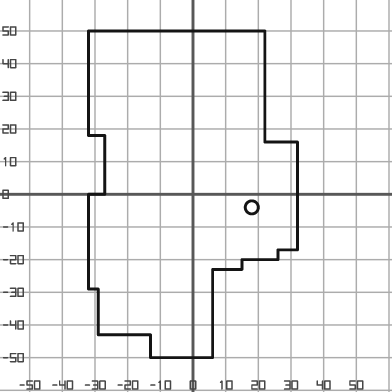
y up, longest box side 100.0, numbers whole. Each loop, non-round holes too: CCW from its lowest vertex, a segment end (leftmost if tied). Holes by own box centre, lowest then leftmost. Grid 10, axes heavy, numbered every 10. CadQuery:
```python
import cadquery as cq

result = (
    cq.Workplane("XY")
    .moveTo(-13.0, -50.0)
    .lineTo(6.0, -50.0)
    .lineTo(6.0, -23.0)
    .lineTo(15.0, -23.0)
    .lineTo(15.0, -20.0)
    .lineTo(26.0, -20.0)
    .lineTo(26.0, -17.0)
    .lineTo(32.0, -17.0)
    .lineTo(32.0, 16.0)
    .lineTo(22.0, 16.0)
    .lineTo(22.0, 50.0)
    .lineTo(-32.0, 50.0)
    .lineTo(-32.0, 18.0)
    .lineTo(-27.0, 18.0)
    .lineTo(-27.0, 0.0)
    .lineTo(-32.0, 0.0)
    .lineTo(-32.0, -29.0)
    .lineTo(-29.0, -29.0)
    .lineTo(-29.0, -43.0)
    .lineTo(-13.0, -43.0)
    .close()
    .moveTo(18.0, -4.0)
    .circle(2.0)
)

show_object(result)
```